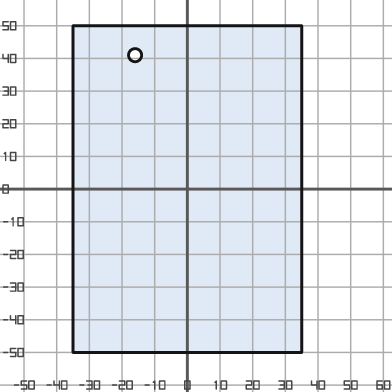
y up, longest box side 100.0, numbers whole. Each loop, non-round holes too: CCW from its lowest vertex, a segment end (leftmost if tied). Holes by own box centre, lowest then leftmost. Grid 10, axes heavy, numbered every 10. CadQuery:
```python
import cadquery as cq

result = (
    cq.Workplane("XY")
    .moveTo(-35.0, -50.0)
    .lineTo(35.0, -50.0)
    .lineTo(35.0, 50.0)
    .lineTo(-35.0, 50.0)
    .close()
    .moveTo(-16.0, 41.0)
    .circle(2.0)
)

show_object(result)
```